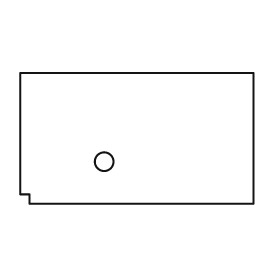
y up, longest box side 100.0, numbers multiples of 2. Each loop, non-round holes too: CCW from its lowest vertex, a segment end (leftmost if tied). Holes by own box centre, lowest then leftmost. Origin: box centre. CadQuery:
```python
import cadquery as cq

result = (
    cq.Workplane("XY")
    .moveTo(-46.0, -28.0)
    .lineTo(50.0, -28.0)
    .lineTo(50.0, 28.0)
    .lineTo(-50.0, 28.0)
    .lineTo(-50.0, -24.0)
    .lineTo(-46.0, -24.0)
    .close()
    .moveTo(-14.0, -10.0)
    .circle(4.0)
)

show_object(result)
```